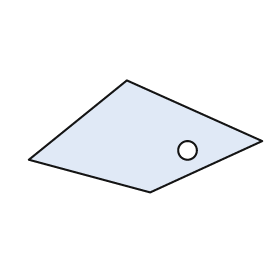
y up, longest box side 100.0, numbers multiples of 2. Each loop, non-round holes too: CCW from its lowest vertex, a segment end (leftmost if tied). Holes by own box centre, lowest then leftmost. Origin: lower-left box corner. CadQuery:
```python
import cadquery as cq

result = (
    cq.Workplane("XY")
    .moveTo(52.0, 0.0)
    .lineTo(100.0, 22.0)
    .lineTo(42.0, 48.0)
    .lineTo(0.0, 14.0)
    .close()
    .moveTo(68.0, 18.0)
    .circle(4.0)
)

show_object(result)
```